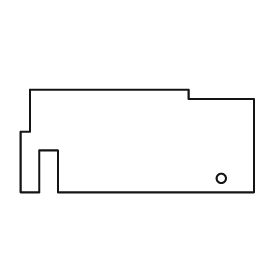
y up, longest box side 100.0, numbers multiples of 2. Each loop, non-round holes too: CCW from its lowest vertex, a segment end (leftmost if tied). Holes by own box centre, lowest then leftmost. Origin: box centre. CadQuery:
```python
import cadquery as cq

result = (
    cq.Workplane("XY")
    .moveTo(-50.0, -22.0)
    .lineTo(-42.0, -22.0)
    .lineTo(-42.0, -4.0)
    .lineTo(-34.0, -4.0)
    .lineTo(-34.0, -22.0)
    .lineTo(50.0, -22.0)
    .lineTo(50.0, 18.0)
    .lineTo(22.0, 18.0)
    .lineTo(22.0, 22.0)
    .lineTo(-46.0, 22.0)
    .lineTo(-46.0, 4.0)
    .lineTo(-50.0, 4.0)
    .close()
    .moveTo(36.0, -16.0)
    .circle(2.0)
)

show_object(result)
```